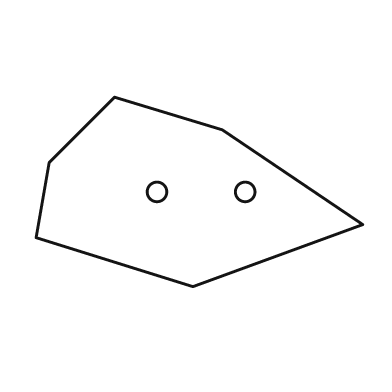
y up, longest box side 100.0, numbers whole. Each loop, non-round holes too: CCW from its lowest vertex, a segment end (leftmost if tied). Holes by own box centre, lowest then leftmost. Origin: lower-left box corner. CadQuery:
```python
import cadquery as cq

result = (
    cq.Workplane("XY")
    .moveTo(48.0, 0.0)
    .lineTo(100.0, 19.0)
    .lineTo(57.0, 48.0)
    .lineTo(24.0, 58.0)
    .lineTo(4.0, 38.0)
    .lineTo(0.0, 15.0)
    .close()
    .moveTo(37.0, 29.0)
    .circle(3.0)
    .moveTo(64.0, 29.0)
    .circle(3.0)
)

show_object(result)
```